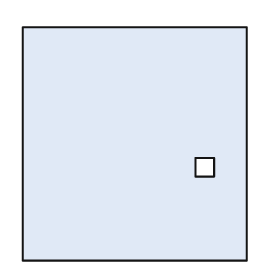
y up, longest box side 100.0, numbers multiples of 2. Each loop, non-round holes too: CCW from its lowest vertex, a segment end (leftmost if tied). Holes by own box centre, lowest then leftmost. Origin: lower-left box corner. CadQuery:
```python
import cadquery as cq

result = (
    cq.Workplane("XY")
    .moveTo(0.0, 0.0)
    .lineTo(96.0, 0.0)
    .lineTo(96.0, 100.0)
    .lineTo(0.0, 100.0)
    .close()
    .moveTo(74.0, 36.0)
    .lineTo(82.0, 36.0)
    .lineTo(82.0, 44.0)
    .lineTo(74.0, 44.0)
    .close()
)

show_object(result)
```